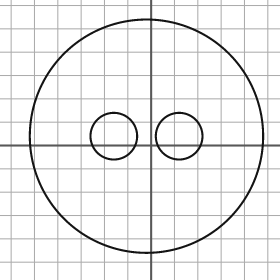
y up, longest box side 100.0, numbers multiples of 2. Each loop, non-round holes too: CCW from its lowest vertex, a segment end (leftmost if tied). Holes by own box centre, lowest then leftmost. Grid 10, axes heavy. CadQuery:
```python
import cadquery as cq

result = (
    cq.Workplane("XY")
    .moveTo(-2.0, 4.0)
    .circle(50.0)
    .moveTo(-16.0, 4.0)
    .circle(10.0)
    .moveTo(12.0, 4.0)
    .circle(10.0)
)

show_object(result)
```